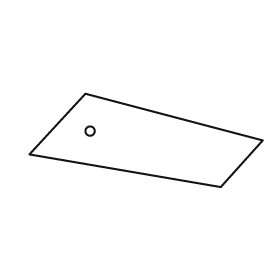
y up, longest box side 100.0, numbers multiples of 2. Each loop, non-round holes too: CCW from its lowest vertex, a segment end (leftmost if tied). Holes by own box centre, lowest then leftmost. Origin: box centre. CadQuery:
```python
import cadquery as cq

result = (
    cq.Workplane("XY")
    .moveTo(32.0, -20.0)
    .lineTo(50.0, 0.0)
    .lineTo(-26.0, 20.0)
    .lineTo(-50.0, -6.0)
    .close()
    .moveTo(-24.0, 4.0)
    .circle(2.0)
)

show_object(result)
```